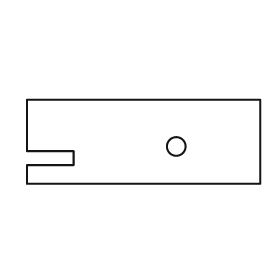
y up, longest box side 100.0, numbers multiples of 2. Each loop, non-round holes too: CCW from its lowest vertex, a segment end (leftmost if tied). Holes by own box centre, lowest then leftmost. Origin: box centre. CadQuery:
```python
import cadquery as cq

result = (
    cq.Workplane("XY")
    .moveTo(-50.0, -18.0)
    .lineTo(50.0, -18.0)
    .lineTo(50.0, 18.0)
    .lineTo(-50.0, 18.0)
    .lineTo(-50.0, -4.0)
    .lineTo(-30.0, -4.0)
    .lineTo(-30.0, -10.0)
    .lineTo(-50.0, -10.0)
    .close()
    .moveTo(14.0, -2.0)
    .circle(4.0)
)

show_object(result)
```